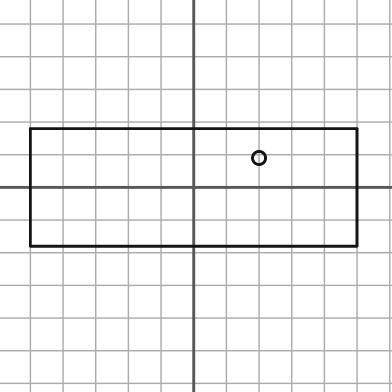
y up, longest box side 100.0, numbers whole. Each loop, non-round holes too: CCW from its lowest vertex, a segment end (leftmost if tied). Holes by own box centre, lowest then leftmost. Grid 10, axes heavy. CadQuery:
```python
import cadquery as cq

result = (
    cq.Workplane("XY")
    .moveTo(-50.0, -18.0)
    .lineTo(50.0, -18.0)
    .lineTo(50.0, 18.0)
    .lineTo(-50.0, 18.0)
    .close()
    .moveTo(20.0, 9.0)
    .circle(2.0)
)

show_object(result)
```